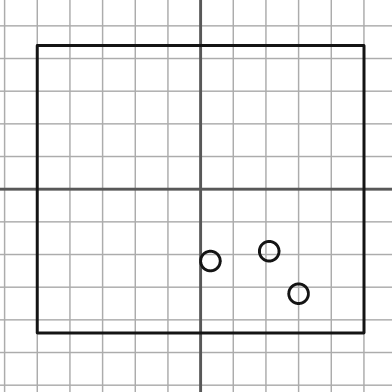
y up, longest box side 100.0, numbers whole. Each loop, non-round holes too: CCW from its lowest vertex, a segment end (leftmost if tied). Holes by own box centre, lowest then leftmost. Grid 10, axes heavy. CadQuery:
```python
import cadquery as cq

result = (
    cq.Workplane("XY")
    .moveTo(-50.0, -44.0)
    .lineTo(50.0, -44.0)
    .lineTo(50.0, 44.0)
    .lineTo(-50.0, 44.0)
    .close()
    .moveTo(30.0, -32.0)
    .circle(3.0)
    .moveTo(3.0, -22.0)
    .circle(3.0)
    .moveTo(21.0, -19.0)
    .circle(3.0)
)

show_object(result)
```